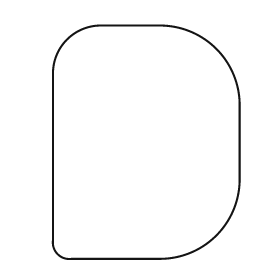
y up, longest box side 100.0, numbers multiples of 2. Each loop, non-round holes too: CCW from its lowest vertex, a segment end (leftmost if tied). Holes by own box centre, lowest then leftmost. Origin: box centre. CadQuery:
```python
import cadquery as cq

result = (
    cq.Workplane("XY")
    .moveTo(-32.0, -50.0)
    .lineTo(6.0, -50.0)
    .threePointArc((30.0, -40.0), (40.0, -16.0))
    .lineTo(40.0, 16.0)
    .threePointArc((30.0, 40.0), (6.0, 50.0))
    .lineTo(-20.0, 50.0)
    .threePointArc((-34.0, 44.0), (-40.0, 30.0))
    .lineTo(-40.0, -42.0)
    .threePointArc((-38.0, -48.0), (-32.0, -50.0))
    .close()
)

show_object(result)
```